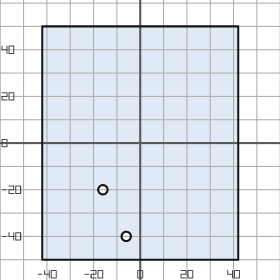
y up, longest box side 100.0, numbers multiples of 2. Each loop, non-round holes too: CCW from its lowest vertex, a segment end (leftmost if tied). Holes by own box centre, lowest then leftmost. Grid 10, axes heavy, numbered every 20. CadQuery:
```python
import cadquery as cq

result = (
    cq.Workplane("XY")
    .moveTo(-42.0, -50.0)
    .lineTo(42.0, -50.0)
    .lineTo(42.0, 50.0)
    .lineTo(-42.0, 50.0)
    .close()
    .moveTo(-6.0, -40.0)
    .circle(2.0)
    .moveTo(-16.0, -20.0)
    .circle(2.0)
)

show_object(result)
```